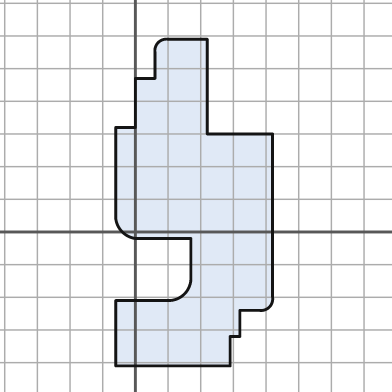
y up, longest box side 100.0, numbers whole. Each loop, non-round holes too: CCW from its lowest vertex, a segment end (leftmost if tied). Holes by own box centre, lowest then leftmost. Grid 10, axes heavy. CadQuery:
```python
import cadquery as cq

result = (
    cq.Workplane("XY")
    .moveTo(-6.0, -41.0)
    .lineTo(29.0, -41.0)
    .lineTo(29.0, -32.0)
    .lineTo(32.0, -32.0)
    .lineTo(32.0, -24.0)
    .lineTo(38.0, -24.0)
    .threePointArc((41.0, -23.0), (42.0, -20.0))
    .lineTo(42.0, 30.0)
    .lineTo(22.0, 30.0)
    .lineTo(22.0, 59.0)
    .lineTo(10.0, 59.0)
    .threePointArc((7.0, 58.0), (6.0, 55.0))
    .lineTo(6.0, 47.0)
    .lineTo(0.0, 47.0)
    .lineTo(0.0, 32.0)
    .lineTo(-6.0, 32.0)
    .lineTo(-6.0, 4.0)
    .threePointArc((-4.0, 0.0), (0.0, -2.0))
    .lineTo(17.0, -2.0)
    .lineTo(17.0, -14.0)
    .threePointArc((15.0, -19.0), (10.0, -21.0))
    .lineTo(-6.0, -21.0)
    .close()
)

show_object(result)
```